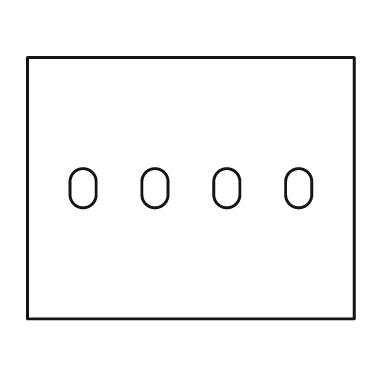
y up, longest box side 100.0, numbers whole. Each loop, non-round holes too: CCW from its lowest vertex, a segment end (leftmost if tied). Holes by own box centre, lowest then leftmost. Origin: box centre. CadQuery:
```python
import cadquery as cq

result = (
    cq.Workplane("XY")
    .moveTo(-50.0, -40.0)
    .lineTo(50.0, -40.0)
    .lineTo(50.0, 40.0)
    .lineTo(-50.0, 40.0)
    .close()
    .moveTo(-37.0, -2.0)
    .threePointArc((-33.0, -6.0), (-29.0, -2.0))
    .lineTo(-29.0, 2.0)
    .threePointArc((-33.0, 6.0), (-37.0, 2.0))
    .close()
    .moveTo(-15.0, -2.0)
    .threePointArc((-11.0, -6.0), (-7.0, -2.0))
    .lineTo(-7.0, 2.0)
    .threePointArc((-11.0, 6.0), (-15.0, 2.0))
    .close()
    .moveTo(7.0, -2.0)
    .threePointArc((11.0, -6.0), (15.0, -2.0))
    .lineTo(15.0, 2.0)
    .threePointArc((11.0, 6.0), (7.0, 2.0))
    .close()
    .moveTo(29.0, -2.0)
    .threePointArc((33.0, -6.0), (37.0, -2.0))
    .lineTo(37.0, 2.0)
    .threePointArc((33.0, 6.0), (29.0, 2.0))
    .close()
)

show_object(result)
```